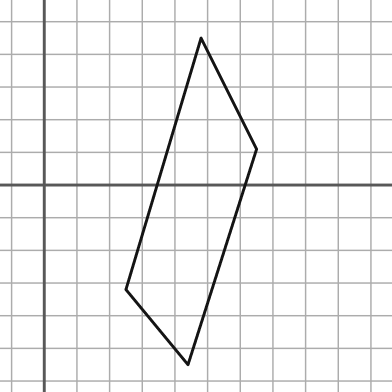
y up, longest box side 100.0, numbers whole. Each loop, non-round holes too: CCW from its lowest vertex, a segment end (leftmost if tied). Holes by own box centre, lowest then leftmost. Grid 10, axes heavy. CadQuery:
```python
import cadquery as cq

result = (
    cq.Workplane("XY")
    .moveTo(44.0, -55.0)
    .lineTo(65.0, 11.0)
    .lineTo(48.0, 45.0)
    .lineTo(25.0, -32.0)
    .close()
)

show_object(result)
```